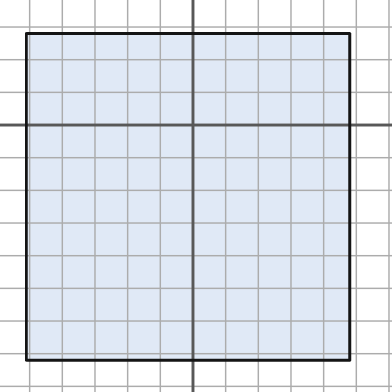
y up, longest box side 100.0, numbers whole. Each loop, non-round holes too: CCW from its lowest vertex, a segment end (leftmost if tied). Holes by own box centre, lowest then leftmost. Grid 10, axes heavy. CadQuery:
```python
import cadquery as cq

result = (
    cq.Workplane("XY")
    .moveTo(-51.0, -72.0)
    .lineTo(48.0, -72.0)
    .lineTo(48.0, 28.0)
    .lineTo(-51.0, 28.0)
    .close()
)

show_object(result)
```